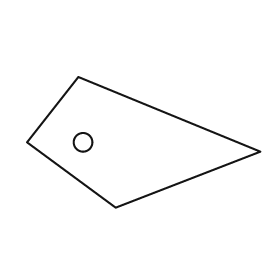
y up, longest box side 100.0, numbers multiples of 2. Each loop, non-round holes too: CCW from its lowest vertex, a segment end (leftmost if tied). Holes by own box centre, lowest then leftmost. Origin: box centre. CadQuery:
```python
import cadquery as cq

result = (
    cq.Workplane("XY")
    .moveTo(-12.0, -28.0)
    .lineTo(50.0, -4.0)
    .lineTo(-28.0, 28.0)
    .lineTo(-50.0, 0.0)
    .close()
    .moveTo(-26.0, 0.0)
    .circle(4.0)
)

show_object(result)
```